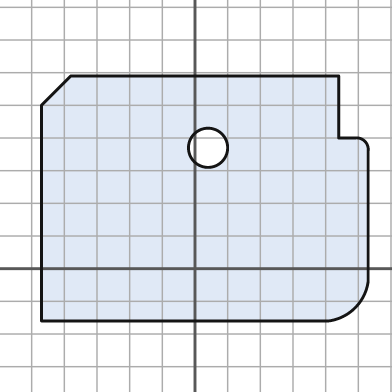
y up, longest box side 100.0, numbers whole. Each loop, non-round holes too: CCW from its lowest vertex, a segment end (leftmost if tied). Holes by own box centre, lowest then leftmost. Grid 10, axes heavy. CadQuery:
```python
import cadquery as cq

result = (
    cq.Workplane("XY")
    .moveTo(-47.0, -16.0)
    .lineTo(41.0, -16.0)
    .threePointArc((49.0, -12.0), (53.0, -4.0))
    .lineTo(53.0, 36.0)
    .threePointArc((52.0, 39.0), (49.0, 40.0))
    .lineTo(44.0, 40.0)
    .lineTo(44.0, 59.0)
    .lineTo(-38.0, 59.0)
    .lineTo(-47.0, 50.0)
    .close()
    .moveTo(4.0, 37.0)
    .circle(6.0)
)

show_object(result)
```